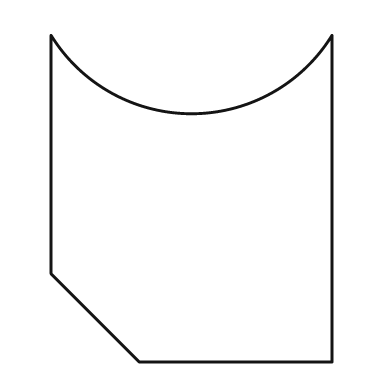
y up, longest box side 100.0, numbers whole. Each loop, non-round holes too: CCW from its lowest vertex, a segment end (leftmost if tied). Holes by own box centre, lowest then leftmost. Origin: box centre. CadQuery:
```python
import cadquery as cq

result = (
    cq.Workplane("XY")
    .moveTo(-16.0, -50.0)
    .lineTo(43.0, -50.0)
    .lineTo(43.0, 50.0)
    .threePointArc((0.0, 26.0), (-43.0, 50.0))
    .lineTo(-43.0, -23.0)
    .close()
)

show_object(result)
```